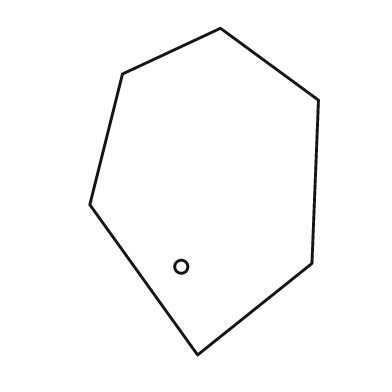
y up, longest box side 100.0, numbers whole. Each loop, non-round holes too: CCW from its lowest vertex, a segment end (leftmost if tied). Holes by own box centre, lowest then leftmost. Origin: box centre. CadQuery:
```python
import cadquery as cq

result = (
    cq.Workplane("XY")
    .moveTo(-2.0, -50.0)
    .lineTo(33.0, -22.0)
    .lineTo(35.0, 28.0)
    .lineTo(5.0, 50.0)
    .lineTo(-25.0, 36.0)
    .lineTo(-35.0, -4.0)
    .close()
    .moveTo(-7.0, -23.0)
    .circle(2.0)
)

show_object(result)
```